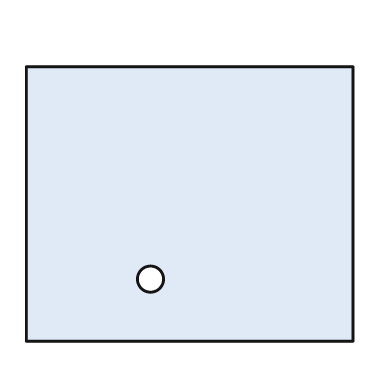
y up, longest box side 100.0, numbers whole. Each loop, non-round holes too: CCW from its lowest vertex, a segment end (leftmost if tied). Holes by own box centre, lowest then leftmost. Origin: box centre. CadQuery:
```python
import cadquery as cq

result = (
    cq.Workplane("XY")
    .moveTo(-50.0, -42.0)
    .lineTo(50.0, -42.0)
    .lineTo(50.0, 42.0)
    .lineTo(-50.0, 42.0)
    .close()
    .moveTo(-12.0, -23.0)
    .circle(4.0)
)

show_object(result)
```